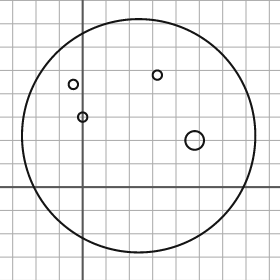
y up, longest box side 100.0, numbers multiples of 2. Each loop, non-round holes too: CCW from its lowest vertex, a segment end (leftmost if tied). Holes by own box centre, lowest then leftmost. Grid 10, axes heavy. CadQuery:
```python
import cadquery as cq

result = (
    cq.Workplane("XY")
    .moveTo(24.0, 22.0)
    .circle(50.0)
    .moveTo(48.0, 20.0)
    .circle(4.0)
    .moveTo(0.0, 30.0)
    .circle(2.0)
    .moveTo(-4.0, 44.0)
    .circle(2.0)
    .moveTo(32.0, 48.0)
    .circle(2.0)
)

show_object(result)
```